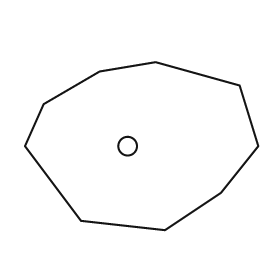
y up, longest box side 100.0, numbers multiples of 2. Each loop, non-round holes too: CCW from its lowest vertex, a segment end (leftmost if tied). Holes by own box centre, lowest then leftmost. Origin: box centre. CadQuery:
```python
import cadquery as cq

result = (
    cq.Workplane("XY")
    .moveTo(10.0, -36.0)
    .lineTo(34.0, -20.0)
    .lineTo(50.0, 0.0)
    .lineTo(42.0, 26.0)
    .lineTo(6.0, 36.0)
    .lineTo(-18.0, 32.0)
    .lineTo(-42.0, 18.0)
    .lineTo(-50.0, 0.0)
    .lineTo(-26.0, -32.0)
    .close()
    .moveTo(-6.0, 0.0)
    .circle(4.0)
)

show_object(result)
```